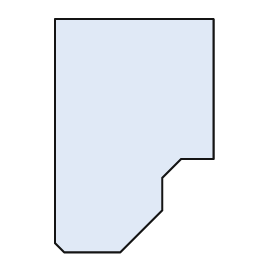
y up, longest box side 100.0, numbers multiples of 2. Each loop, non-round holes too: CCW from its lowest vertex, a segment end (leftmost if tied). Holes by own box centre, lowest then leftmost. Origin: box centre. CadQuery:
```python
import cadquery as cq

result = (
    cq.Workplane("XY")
    .moveTo(-30.0, -50.0)
    .lineTo(-6.0, -50.0)
    .lineTo(12.0, -32.0)
    .lineTo(12.0, -18.0)
    .lineTo(20.0, -10.0)
    .lineTo(34.0, -10.0)
    .lineTo(34.0, 50.0)
    .lineTo(-34.0, 50.0)
    .lineTo(-34.0, -46.0)
    .close()
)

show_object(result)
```